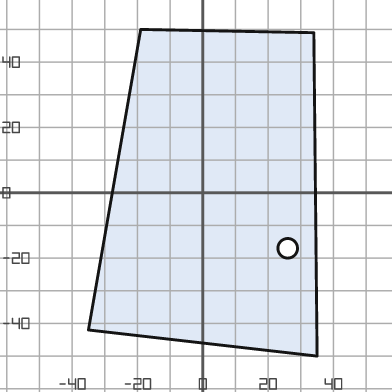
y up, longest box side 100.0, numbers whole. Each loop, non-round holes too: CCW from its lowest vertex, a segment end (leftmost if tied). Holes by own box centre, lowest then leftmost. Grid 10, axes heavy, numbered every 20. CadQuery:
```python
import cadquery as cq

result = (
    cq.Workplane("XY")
    .moveTo(35.0, -50.0)
    .lineTo(34.0, 49.0)
    .lineTo(-19.0, 50.0)
    .lineTo(-35.0, -42.0)
    .close()
    .moveTo(26.0, -17.0)
    .circle(3.0)
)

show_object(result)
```